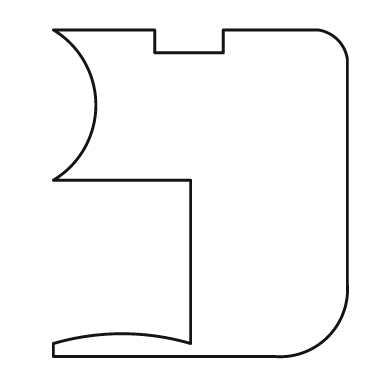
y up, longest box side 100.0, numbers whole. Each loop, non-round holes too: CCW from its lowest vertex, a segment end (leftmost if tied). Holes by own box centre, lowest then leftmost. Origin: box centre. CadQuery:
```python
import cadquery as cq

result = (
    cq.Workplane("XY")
    .moveTo(-45.0, -50.0)
    .lineTo(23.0, -50.0)
    .threePointArc((39.0, -44.0), (45.0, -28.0))
    .lineTo(45.0, 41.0)
    .threePointArc((42.0, 47.0), (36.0, 50.0))
    .lineTo(7.0, 50.0)
    .lineTo(7.0, 43.0)
    .lineTo(-14.0, 43.0)
    .lineTo(-14.0, 50.0)
    .lineTo(-45.0, 50.0)
    .threePointArc((-32.0, 27.0), (-45.0, 4.0))
    .lineTo(-3.0, 4.0)
    .lineTo(-3.0, -46.0)
    .threePointArc((-24.0, -43.0), (-45.0, -46.0))
    .close()
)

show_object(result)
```